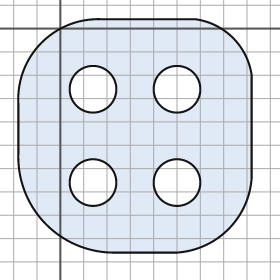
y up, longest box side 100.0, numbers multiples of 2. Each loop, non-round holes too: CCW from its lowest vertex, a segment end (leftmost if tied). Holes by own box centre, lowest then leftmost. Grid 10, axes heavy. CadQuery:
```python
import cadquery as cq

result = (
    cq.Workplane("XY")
    .moveTo(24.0, -96.0)
    .lineTo(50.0, -96.0)
    .threePointArc((72.0, -86.0), (82.0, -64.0))
    .lineTo(82.0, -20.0)
    .threePointArc((74.0, -4.0), (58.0, 4.0))
    .lineTo(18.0, 4.0)
    .threePointArc((-8.0, -6.0), (-18.0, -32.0))
    .lineTo(-18.0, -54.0)
    .threePointArc((-6.0, -84.0), (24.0, -96.0))
    .close()
    .moveTo(14.0, -66.0)
    .circle(10.0)
    .moveTo(50.0, -66.0)
    .circle(10.0)
    .moveTo(14.0, -26.0)
    .circle(10.0)
    .moveTo(50.0, -26.0)
    .circle(10.0)
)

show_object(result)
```